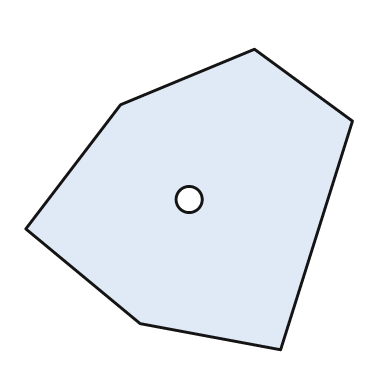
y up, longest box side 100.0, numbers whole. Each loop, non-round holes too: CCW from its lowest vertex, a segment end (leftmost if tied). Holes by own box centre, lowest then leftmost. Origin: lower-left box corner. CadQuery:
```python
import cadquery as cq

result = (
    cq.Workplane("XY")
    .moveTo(78.0, 0.0)
    .lineTo(100.0, 70.0)
    .lineTo(70.0, 92.0)
    .lineTo(29.0, 75.0)
    .lineTo(0.0, 37.0)
    .lineTo(35.0, 8.0)
    .close()
    .moveTo(50.0, 46.0)
    .circle(4.0)
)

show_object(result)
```